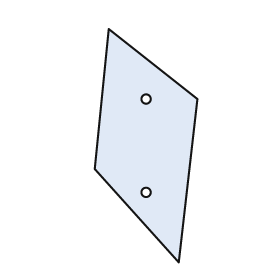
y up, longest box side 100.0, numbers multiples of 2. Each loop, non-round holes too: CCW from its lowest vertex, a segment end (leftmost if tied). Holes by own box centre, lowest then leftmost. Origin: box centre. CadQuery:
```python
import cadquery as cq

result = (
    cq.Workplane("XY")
    .moveTo(14.0, -50.0)
    .lineTo(22.0, 20.0)
    .lineTo(-16.0, 50.0)
    .lineTo(-22.0, -10.0)
    .close()
    .moveTo(0.0, -20.0)
    .circle(2.0)
    .moveTo(0.0, 20.0)
    .circle(2.0)
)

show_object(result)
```